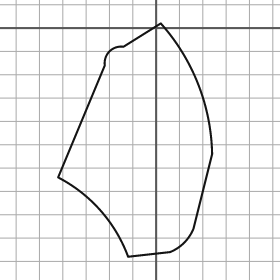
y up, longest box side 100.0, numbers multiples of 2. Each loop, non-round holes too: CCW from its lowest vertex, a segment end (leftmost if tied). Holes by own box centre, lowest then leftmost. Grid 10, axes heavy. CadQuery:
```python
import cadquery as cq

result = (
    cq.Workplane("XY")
    .moveTo(-12.0, -98.0)
    .lineTo(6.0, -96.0)
    .threePointArc((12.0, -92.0), (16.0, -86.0))
    .lineTo(24.0, -54.0)
    .threePointArc((18.0, -24.0), (2.0, 2.0))
    .lineTo(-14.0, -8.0)
    .threePointArc((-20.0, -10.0), (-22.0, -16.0))
    .lineTo(-42.0, -64.0)
    .threePointArc((-24.0, -78.0), (-12.0, -98.0))
    .close()
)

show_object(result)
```